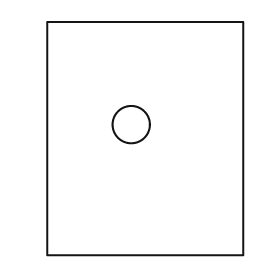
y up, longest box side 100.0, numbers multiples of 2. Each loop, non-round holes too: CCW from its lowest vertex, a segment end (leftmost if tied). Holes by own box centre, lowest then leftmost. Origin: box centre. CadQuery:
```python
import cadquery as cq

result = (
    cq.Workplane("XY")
    .moveTo(-42.0, -50.0)
    .lineTo(42.0, -50.0)
    .lineTo(42.0, 50.0)
    .lineTo(-42.0, 50.0)
    .close()
    .moveTo(-6.0, 6.0)
    .circle(8.0)
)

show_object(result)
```